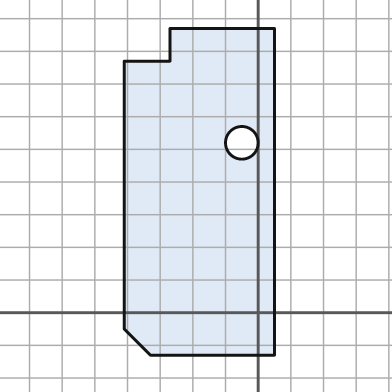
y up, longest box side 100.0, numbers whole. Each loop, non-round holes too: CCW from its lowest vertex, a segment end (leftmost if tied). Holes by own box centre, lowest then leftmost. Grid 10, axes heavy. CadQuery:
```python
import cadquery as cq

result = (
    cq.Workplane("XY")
    .moveTo(-33.0, -13.0)
    .lineTo(5.0, -13.0)
    .lineTo(5.0, 87.0)
    .lineTo(-27.0, 87.0)
    .lineTo(-27.0, 77.0)
    .lineTo(-41.0, 77.0)
    .lineTo(-41.0, -5.0)
    .close()
    .moveTo(-5.0, 52.0)
    .circle(5.0)
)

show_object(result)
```